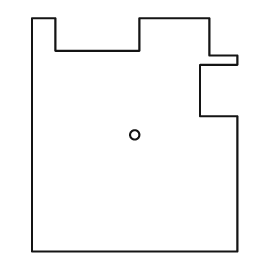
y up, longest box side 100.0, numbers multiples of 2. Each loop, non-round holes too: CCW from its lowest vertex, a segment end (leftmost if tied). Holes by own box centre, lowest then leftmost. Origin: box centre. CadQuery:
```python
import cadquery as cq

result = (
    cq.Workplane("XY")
    .moveTo(-44.0, -50.0)
    .lineTo(44.0, -50.0)
    .lineTo(44.0, 8.0)
    .lineTo(28.0, 8.0)
    .lineTo(28.0, 30.0)
    .lineTo(44.0, 30.0)
    .lineTo(44.0, 34.0)
    .lineTo(32.0, 34.0)
    .lineTo(32.0, 50.0)
    .lineTo(2.0, 50.0)
    .lineTo(2.0, 36.0)
    .lineTo(-34.0, 36.0)
    .lineTo(-34.0, 50.0)
    .lineTo(-44.0, 50.0)
    .close()
    .moveTo(0.0, 0.0)
    .circle(2.0)
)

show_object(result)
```